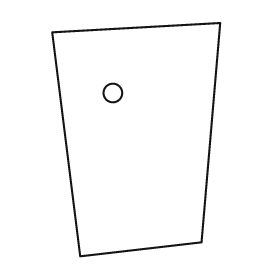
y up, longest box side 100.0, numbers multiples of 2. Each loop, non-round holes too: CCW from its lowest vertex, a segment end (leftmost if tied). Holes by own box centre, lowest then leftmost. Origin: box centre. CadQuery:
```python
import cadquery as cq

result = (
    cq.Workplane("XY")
    .moveTo(-24.0, -50.0)
    .lineTo(28.0, -44.0)
    .lineTo(36.0, 50.0)
    .lineTo(-36.0, 46.0)
    .close()
    .moveTo(-10.0, 20.0)
    .circle(4.0)
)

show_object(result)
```